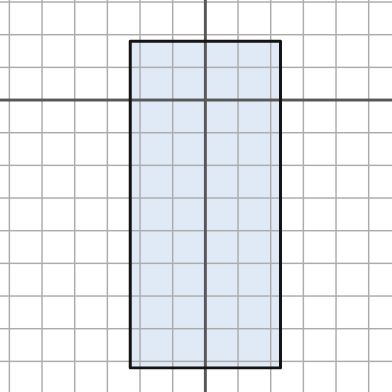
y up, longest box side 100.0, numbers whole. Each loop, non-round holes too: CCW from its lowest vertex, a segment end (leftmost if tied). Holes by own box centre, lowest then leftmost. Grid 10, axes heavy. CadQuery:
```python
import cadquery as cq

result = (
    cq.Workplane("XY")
    .moveTo(-23.0, -82.0)
    .lineTo(23.0, -82.0)
    .lineTo(23.0, 18.0)
    .lineTo(-23.0, 18.0)
    .close()
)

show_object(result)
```